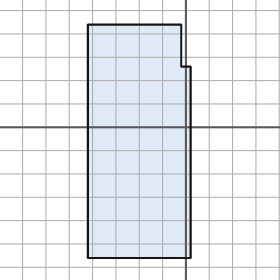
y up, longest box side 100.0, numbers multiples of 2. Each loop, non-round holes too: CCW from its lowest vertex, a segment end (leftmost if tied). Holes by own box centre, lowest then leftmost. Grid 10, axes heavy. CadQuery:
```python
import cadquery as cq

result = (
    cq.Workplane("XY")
    .moveTo(-42.0, -56.0)
    .lineTo(2.0, -56.0)
    .lineTo(2.0, 26.0)
    .lineTo(-2.0, 26.0)
    .lineTo(-2.0, 44.0)
    .lineTo(-42.0, 44.0)
    .close()
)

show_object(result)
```